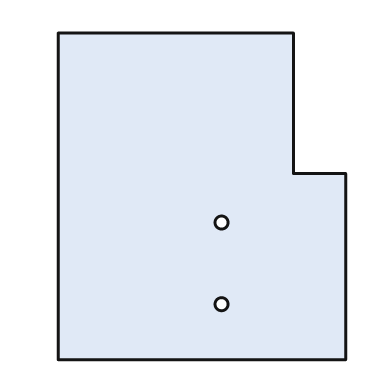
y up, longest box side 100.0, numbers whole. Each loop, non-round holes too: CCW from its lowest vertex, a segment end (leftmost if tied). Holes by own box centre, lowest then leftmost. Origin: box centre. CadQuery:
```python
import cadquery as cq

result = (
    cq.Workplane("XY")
    .moveTo(-44.0, -50.0)
    .lineTo(44.0, -50.0)
    .lineTo(44.0, 7.0)
    .lineTo(28.0, 7.0)
    .lineTo(28.0, 50.0)
    .lineTo(-44.0, 50.0)
    .close()
    .moveTo(6.0, -33.0)
    .circle(2.0)
    .moveTo(6.0, -8.0)
    .circle(2.0)
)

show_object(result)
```